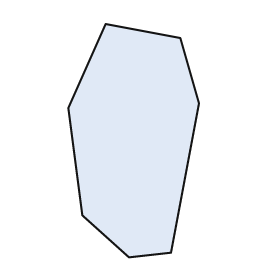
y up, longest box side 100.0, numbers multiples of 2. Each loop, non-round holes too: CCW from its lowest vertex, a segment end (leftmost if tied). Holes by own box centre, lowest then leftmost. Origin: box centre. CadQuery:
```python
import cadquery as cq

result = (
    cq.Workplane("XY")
    .moveTo(-2.0, -50.0)
    .lineTo(16.0, -48.0)
    .lineTo(28.0, 16.0)
    .lineTo(20.0, 44.0)
    .lineTo(-12.0, 50.0)
    .lineTo(-28.0, 14.0)
    .lineTo(-22.0, -32.0)
    .close()
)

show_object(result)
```